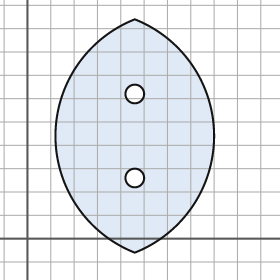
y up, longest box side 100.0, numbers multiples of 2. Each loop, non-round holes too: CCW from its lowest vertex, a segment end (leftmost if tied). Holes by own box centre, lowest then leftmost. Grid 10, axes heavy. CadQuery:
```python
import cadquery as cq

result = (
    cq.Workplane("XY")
    .moveTo(46.0, -6.0)
    .threePointArc((80.0, 44.0), (46.0, 94.0))
    .threePointArc((12.0, 44.0), (46.0, -6.0))
    .close()
    .moveTo(46.0, 26.0)
    .circle(4.0)
    .moveTo(46.0, 62.0)
    .circle(4.0)
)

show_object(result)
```